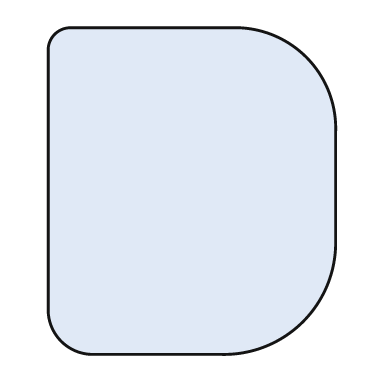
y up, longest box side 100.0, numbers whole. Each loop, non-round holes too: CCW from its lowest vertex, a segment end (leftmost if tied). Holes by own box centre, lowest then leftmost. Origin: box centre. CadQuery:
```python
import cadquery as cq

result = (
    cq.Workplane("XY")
    .moveTo(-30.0, -50.0)
    .lineTo(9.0, -50.0)
    .threePointArc((34.0, -40.0), (44.0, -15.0))
    .lineTo(44.0, 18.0)
    .threePointArc((35.0, 41.0), (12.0, 50.0))
    .lineTo(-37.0, 50.0)
    .threePointArc((-42.0, 48.0), (-44.0, 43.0))
    .lineTo(-44.0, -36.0)
    .threePointArc((-40.0, -46.0), (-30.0, -50.0))
    .close()
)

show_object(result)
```